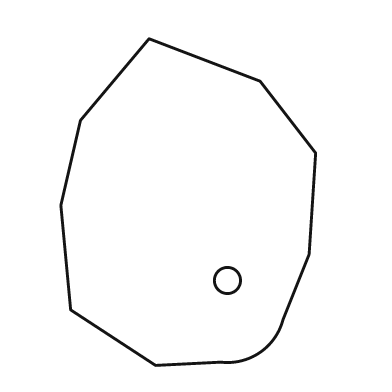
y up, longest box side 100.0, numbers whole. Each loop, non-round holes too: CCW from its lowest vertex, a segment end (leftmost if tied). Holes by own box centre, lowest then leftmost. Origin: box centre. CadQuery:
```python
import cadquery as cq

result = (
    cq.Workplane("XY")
    .moveTo(-10.0, -50.0)
    .lineTo(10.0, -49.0)
    .threePointArc((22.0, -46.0), (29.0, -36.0))
    .lineTo(37.0, -16.0)
    .lineTo(39.0, 15.0)
    .lineTo(22.0, 37.0)
    .lineTo(-12.0, 50.0)
    .lineTo(-33.0, 25.0)
    .lineTo(-39.0, -1.0)
    .lineTo(-36.0, -33.0)
    .close()
    .moveTo(12.0, -24.0)
    .circle(4.0)
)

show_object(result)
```